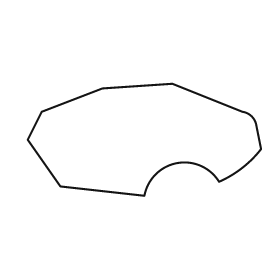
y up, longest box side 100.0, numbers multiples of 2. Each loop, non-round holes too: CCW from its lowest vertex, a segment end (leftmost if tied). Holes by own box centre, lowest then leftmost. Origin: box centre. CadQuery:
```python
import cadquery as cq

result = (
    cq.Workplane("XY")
    .moveTo(0.0, -24.0)
    .threePointArc((14.0, -10.0), (32.0, -18.0))
    .threePointArc((42.0, -12.0), (50.0, -4.0))
    .lineTo(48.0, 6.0)
    .threePointArc((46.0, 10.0), (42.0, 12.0))
    .lineTo(12.0, 24.0)
    .lineTo(-18.0, 22.0)
    .lineTo(-44.0, 12.0)
    .lineTo(-50.0, 0.0)
    .lineTo(-36.0, -20.0)
    .close()
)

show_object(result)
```